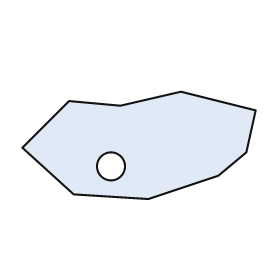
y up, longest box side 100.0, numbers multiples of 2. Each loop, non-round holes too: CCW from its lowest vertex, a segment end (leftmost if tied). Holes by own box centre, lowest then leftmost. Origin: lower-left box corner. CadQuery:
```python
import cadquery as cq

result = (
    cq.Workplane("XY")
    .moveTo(54.0, 0.0)
    .lineTo(84.0, 10.0)
    .lineTo(96.0, 20.0)
    .lineTo(100.0, 38.0)
    .lineTo(68.0, 46.0)
    .lineTo(42.0, 40.0)
    .lineTo(20.0, 42.0)
    .lineTo(0.0, 22.0)
    .lineTo(22.0, 2.0)
    .close()
    .moveTo(38.0, 14.0)
    .circle(6.0)
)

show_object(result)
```